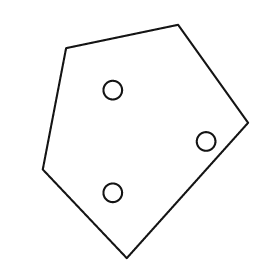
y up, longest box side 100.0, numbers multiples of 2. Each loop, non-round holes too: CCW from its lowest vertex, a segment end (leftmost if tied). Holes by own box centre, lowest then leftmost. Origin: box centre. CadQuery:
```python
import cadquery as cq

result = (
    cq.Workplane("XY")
    .moveTo(-8.0, -50.0)
    .lineTo(44.0, 8.0)
    .lineTo(14.0, 50.0)
    .lineTo(-34.0, 40.0)
    .lineTo(-44.0, -12.0)
    .close()
    .moveTo(-14.0, -22.0)
    .circle(4.0)
    .moveTo(26.0, 0.0)
    .circle(4.0)
    .moveTo(-14.0, 22.0)
    .circle(4.0)
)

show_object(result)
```